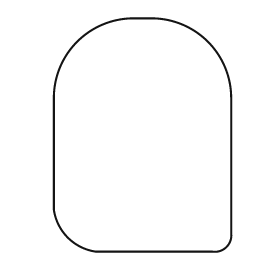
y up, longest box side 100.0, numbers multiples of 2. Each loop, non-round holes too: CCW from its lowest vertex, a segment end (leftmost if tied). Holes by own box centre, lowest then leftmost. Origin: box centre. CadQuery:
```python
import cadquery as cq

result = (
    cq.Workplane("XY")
    .moveTo(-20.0, -50.0)
    .lineTo(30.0, -50.0)
    .threePointArc((36.0, -48.0), (38.0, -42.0))
    .lineTo(38.0, 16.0)
    .threePointArc((28.0, 40.0), (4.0, 50.0))
    .lineTo(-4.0, 50.0)
    .threePointArc((-28.0, 40.0), (-38.0, 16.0))
    .lineTo(-38.0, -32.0)
    .threePointArc((-32.0, -44.0), (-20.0, -50.0))
    .close()
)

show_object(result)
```